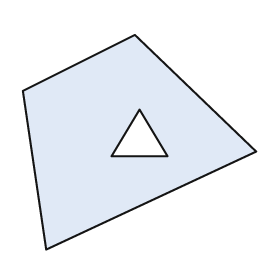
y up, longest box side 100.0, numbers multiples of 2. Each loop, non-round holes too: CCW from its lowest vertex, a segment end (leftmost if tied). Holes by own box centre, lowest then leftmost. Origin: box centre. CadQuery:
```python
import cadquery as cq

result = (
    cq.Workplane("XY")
    .moveTo(-40.0, -46.0)
    .lineTo(50.0, -4.0)
    .lineTo(-2.0, 46.0)
    .lineTo(-50.0, 22.0)
    .close()
    .moveTo(-12.0, -6.0)
    .lineTo(12.0, -6.0)
    .lineTo(0.0, 14.0)
    .close()
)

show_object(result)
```